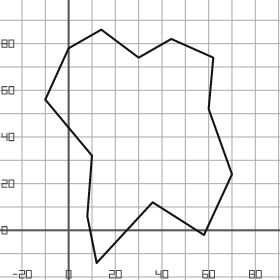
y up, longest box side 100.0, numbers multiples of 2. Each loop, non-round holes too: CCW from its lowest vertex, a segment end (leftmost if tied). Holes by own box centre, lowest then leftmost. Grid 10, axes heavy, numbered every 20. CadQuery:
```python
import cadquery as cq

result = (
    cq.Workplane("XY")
    .moveTo(12.0, -14.0)
    .lineTo(36.0, 12.0)
    .lineTo(58.0, -2.0)
    .lineTo(70.0, 24.0)
    .lineTo(60.0, 52.0)
    .lineTo(62.0, 74.0)
    .lineTo(44.0, 82.0)
    .lineTo(30.0, 74.0)
    .lineTo(14.0, 86.0)
    .lineTo(0.0, 78.0)
    .lineTo(-10.0, 56.0)
    .lineTo(10.0, 32.0)
    .lineTo(8.0, 6.0)
    .close()
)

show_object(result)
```